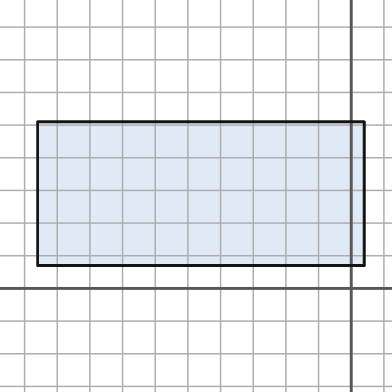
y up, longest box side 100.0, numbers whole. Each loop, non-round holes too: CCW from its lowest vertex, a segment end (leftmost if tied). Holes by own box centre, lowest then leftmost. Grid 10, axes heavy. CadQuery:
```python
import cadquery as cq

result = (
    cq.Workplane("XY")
    .moveTo(-96.0, 7.0)
    .lineTo(4.0, 7.0)
    .lineTo(4.0, 51.0)
    .lineTo(-96.0, 51.0)
    .close()
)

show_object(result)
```